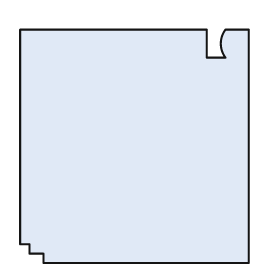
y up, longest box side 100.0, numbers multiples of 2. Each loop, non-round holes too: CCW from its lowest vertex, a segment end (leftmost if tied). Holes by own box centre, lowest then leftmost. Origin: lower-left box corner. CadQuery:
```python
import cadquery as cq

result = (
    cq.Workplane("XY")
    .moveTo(10.0, 0.0)
    .lineTo(98.0, 0.0)
    .lineTo(98.0, 100.0)
    .lineTo(88.0, 100.0)
    .threePointArc((86.0, 94.0), (88.0, 88.0))
    .lineTo(80.0, 88.0)
    .lineTo(80.0, 100.0)
    .lineTo(0.0, 100.0)
    .lineTo(0.0, 8.0)
    .lineTo(4.0, 8.0)
    .lineTo(4.0, 4.0)
    .lineTo(10.0, 4.0)
    .close()
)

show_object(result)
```